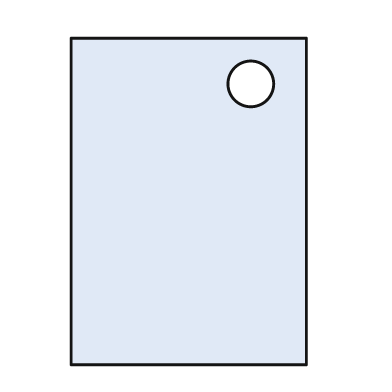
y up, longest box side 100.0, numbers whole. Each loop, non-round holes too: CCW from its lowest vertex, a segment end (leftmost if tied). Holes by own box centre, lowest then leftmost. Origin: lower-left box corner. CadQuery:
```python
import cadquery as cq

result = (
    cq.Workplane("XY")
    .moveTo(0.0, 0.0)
    .lineTo(72.0, 0.0)
    .lineTo(72.0, 100.0)
    .lineTo(0.0, 100.0)
    .close()
    .moveTo(55.0, 86.0)
    .circle(7.0)
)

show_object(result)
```